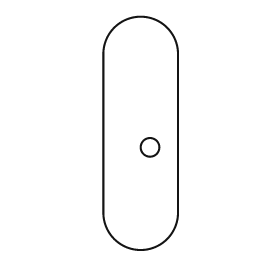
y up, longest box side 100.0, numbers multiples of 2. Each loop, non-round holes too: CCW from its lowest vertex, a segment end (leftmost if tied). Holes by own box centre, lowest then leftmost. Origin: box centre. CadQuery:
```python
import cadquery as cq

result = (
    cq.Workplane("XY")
    .moveTo(-16.0, -34.0)
    .threePointArc((0.0, -50.0), (16.0, -34.0))
    .lineTo(16.0, 34.0)
    .threePointArc((0.0, 50.0), (-16.0, 34.0))
    .close()
    .moveTo(4.0, -6.0)
    .circle(4.0)
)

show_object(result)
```